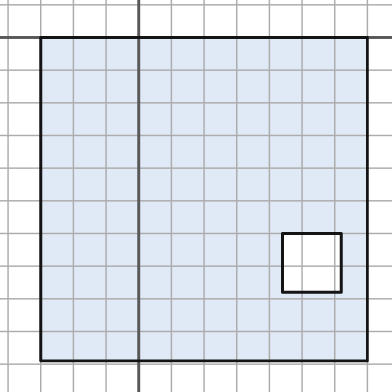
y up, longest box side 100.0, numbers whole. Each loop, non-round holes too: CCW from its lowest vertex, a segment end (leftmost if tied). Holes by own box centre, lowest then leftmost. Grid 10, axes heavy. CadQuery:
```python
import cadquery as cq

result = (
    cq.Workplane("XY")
    .moveTo(-30.0, -99.0)
    .lineTo(70.0, -99.0)
    .lineTo(70.0, 0.0)
    .lineTo(-30.0, 0.0)
    .close()
    .moveTo(44.0, -78.0)
    .lineTo(62.0, -78.0)
    .lineTo(62.0, -60.0)
    .lineTo(44.0, -60.0)
    .close()
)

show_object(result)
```